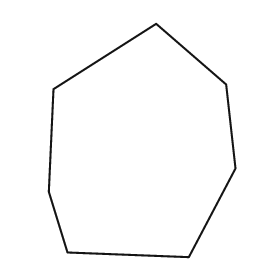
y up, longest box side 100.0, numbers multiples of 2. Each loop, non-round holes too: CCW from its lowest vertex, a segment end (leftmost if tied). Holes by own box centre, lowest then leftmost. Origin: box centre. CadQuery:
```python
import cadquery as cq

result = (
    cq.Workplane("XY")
    .moveTo(20.0, -50.0)
    .lineTo(40.0, -12.0)
    .lineTo(36.0, 24.0)
    .lineTo(6.0, 50.0)
    .lineTo(-38.0, 22.0)
    .lineTo(-40.0, -22.0)
    .lineTo(-32.0, -48.0)
    .close()
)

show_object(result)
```